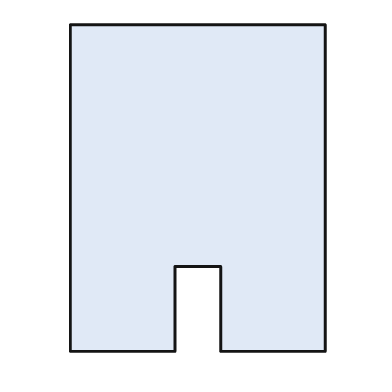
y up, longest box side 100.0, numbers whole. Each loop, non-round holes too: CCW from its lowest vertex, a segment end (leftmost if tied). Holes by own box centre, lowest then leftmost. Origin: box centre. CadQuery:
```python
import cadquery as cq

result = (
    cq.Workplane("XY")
    .moveTo(-39.0, -50.0)
    .lineTo(-7.0, -50.0)
    .lineTo(-7.0, -24.0)
    .lineTo(7.0, -24.0)
    .lineTo(7.0, -50.0)
    .lineTo(39.0, -50.0)
    .lineTo(39.0, 50.0)
    .lineTo(-39.0, 50.0)
    .close()
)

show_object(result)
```